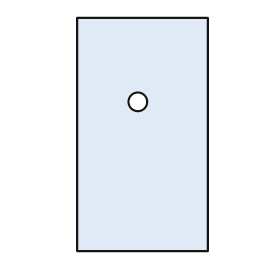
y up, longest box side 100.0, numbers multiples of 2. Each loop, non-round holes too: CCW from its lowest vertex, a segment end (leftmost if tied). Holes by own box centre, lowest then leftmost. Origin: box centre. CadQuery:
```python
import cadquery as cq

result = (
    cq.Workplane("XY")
    .moveTo(-28.0, -50.0)
    .lineTo(28.0, -50.0)
    .lineTo(28.0, 50.0)
    .lineTo(-28.0, 50.0)
    .close()
    .moveTo(-2.0, 14.0)
    .circle(4.0)
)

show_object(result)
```